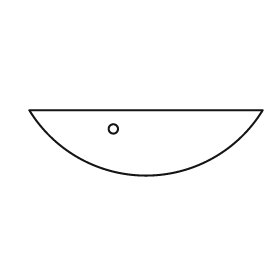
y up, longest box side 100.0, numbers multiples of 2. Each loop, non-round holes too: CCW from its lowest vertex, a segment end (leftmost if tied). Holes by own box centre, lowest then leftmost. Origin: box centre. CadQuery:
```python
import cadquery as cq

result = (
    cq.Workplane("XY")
    .moveTo(-50.0, 14.0)
    .threePointArc((0.0, -14.0), (50.0, 14.0))
    .close()
    .moveTo(-14.0, 6.0)
    .circle(2.0)
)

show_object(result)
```